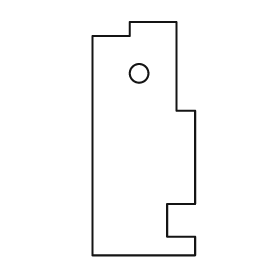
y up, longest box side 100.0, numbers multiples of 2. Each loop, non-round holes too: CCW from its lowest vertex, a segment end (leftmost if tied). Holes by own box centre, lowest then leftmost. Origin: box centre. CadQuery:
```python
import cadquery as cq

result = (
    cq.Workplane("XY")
    .moveTo(-22.0, -50.0)
    .lineTo(22.0, -50.0)
    .lineTo(22.0, -42.0)
    .lineTo(10.0, -42.0)
    .lineTo(10.0, -28.0)
    .lineTo(22.0, -28.0)
    .lineTo(22.0, 12.0)
    .lineTo(14.0, 12.0)
    .lineTo(14.0, 50.0)
    .lineTo(-6.0, 50.0)
    .lineTo(-6.0, 44.0)
    .lineTo(-22.0, 44.0)
    .close()
    .moveTo(-2.0, 28.0)
    .circle(4.0)
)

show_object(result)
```